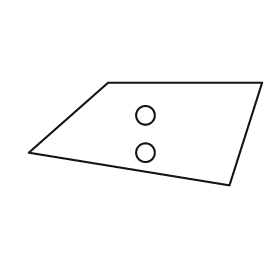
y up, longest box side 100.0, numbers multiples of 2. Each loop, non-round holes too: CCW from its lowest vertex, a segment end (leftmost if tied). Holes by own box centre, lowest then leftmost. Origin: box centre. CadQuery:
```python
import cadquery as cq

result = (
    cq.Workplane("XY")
    .moveTo(36.0, -22.0)
    .lineTo(50.0, 22.0)
    .lineTo(-16.0, 22.0)
    .lineTo(-50.0, -8.0)
    .close()
    .moveTo(0.0, -8.0)
    .circle(4.0)
    .moveTo(0.0, 8.0)
    .circle(4.0)
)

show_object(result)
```